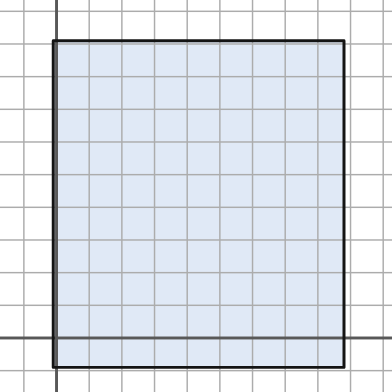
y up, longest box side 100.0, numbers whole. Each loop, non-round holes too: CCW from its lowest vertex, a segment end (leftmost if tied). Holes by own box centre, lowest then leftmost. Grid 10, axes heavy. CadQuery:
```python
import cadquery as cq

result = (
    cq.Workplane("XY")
    .moveTo(-1.0, -9.0)
    .lineTo(88.0, -9.0)
    .lineTo(88.0, 91.0)
    .lineTo(-1.0, 91.0)
    .close()
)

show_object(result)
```